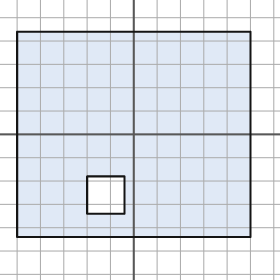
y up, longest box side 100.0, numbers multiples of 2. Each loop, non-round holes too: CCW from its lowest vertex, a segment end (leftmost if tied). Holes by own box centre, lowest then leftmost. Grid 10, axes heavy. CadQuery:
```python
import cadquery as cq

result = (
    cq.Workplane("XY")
    .moveTo(-50.0, -44.0)
    .lineTo(50.0, -44.0)
    .lineTo(50.0, 44.0)
    .lineTo(-50.0, 44.0)
    .close()
    .moveTo(-20.0, -34.0)
    .lineTo(-4.0, -34.0)
    .lineTo(-4.0, -18.0)
    .lineTo(-20.0, -18.0)
    .close()
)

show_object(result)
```